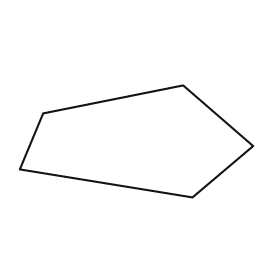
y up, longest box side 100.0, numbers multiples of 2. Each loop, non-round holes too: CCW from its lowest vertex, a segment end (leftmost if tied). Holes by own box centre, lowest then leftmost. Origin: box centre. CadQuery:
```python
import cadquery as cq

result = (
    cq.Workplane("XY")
    .moveTo(24.0, -24.0)
    .lineTo(50.0, -2.0)
    .lineTo(20.0, 24.0)
    .lineTo(-40.0, 12.0)
    .lineTo(-50.0, -12.0)
    .close()
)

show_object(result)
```